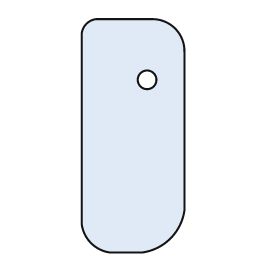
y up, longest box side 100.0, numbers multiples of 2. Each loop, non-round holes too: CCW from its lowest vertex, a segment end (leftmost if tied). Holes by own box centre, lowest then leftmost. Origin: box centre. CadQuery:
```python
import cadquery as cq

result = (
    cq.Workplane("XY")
    .moveTo(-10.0, -50.0)
    .lineTo(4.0, -50.0)
    .threePointArc((16.0, -44.0), (22.0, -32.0))
    .lineTo(22.0, 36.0)
    .threePointArc((18.0, 46.0), (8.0, 50.0))
    .lineTo(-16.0, 50.0)
    .threePointArc((-20.0, 48.0), (-22.0, 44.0))
    .lineTo(-22.0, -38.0)
    .threePointArc((-18.0, -46.0), (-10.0, -50.0))
    .close()
    .moveTo(6.0, 24.0)
    .circle(4.0)
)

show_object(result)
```